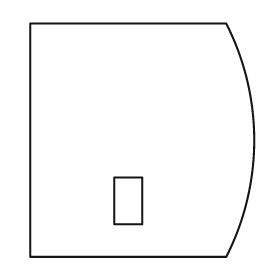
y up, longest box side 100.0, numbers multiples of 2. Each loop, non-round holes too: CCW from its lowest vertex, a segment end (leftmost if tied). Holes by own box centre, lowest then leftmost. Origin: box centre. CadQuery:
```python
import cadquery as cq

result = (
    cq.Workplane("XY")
    .moveTo(-48.0, -50.0)
    .lineTo(36.0, -50.0)
    .threePointArc((48.0, 0.0), (36.0, 50.0))
    .lineTo(-48.0, 50.0)
    .close()
    .moveTo(-12.0, -36.0)
    .lineTo(0.0, -36.0)
    .lineTo(0.0, -16.0)
    .lineTo(-12.0, -16.0)
    .close()
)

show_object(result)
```